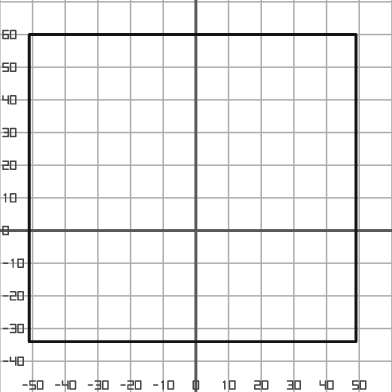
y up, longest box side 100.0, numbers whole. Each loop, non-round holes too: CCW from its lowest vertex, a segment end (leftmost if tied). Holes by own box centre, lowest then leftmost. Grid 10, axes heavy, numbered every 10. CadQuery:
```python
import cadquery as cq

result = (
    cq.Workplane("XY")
    .moveTo(-51.0, -34.0)
    .lineTo(49.0, -34.0)
    .lineTo(49.0, 60.0)
    .lineTo(-51.0, 60.0)
    .close()
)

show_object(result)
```